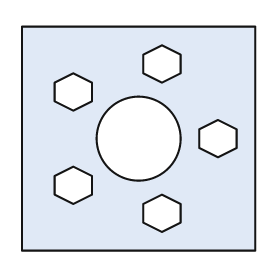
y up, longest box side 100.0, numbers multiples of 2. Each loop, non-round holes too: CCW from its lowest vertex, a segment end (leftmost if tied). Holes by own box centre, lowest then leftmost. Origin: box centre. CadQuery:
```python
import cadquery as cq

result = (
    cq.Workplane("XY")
    .moveTo(-50.0, -48.0)
    .lineTo(50.0, -48.0)
    .lineTo(50.0, 48.0)
    .lineTo(-50.0, 48.0)
    .close()
    .moveTo(10.0, -40.0)
    .lineTo(18.0, -36.0)
    .lineTo(18.0, -28.0)
    .lineTo(10.0, -24.0)
    .lineTo(2.0, -28.0)
    .lineTo(2.0, -36.0)
    .close()
    .moveTo(-28.0, -28.0)
    .lineTo(-20.0, -24.0)
    .lineTo(-20.0, -16.0)
    .lineTo(-28.0, -12.0)
    .lineTo(-36.0, -16.0)
    .lineTo(-36.0, -24.0)
    .close()
    .moveTo(0.0, 0.0)
    .circle(18.0)
    .moveTo(34.0, -8.0)
    .lineTo(42.0, -4.0)
    .lineTo(42.0, 4.0)
    .lineTo(34.0, 8.0)
    .lineTo(26.0, 4.0)
    .lineTo(26.0, -4.0)
    .close()
    .moveTo(-28.0, 12.0)
    .lineTo(-20.0, 16.0)
    .lineTo(-20.0, 24.0)
    .lineTo(-28.0, 28.0)
    .lineTo(-36.0, 24.0)
    .lineTo(-36.0, 16.0)
    .close()
    .moveTo(10.0, 24.0)
    .lineTo(18.0, 28.0)
    .lineTo(18.0, 36.0)
    .lineTo(10.0, 40.0)
    .lineTo(2.0, 36.0)
    .lineTo(2.0, 28.0)
    .close()
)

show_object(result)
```